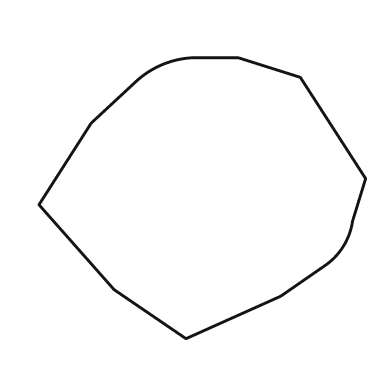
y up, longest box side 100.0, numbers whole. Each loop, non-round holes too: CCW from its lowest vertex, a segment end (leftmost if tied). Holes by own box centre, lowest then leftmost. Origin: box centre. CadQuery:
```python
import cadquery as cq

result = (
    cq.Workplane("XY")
    .moveTo(-5.0, -43.0)
    .lineTo(24.0, -30.0)
    .lineTo(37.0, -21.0)
    .threePointArc((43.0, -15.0), (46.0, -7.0))
    .lineTo(50.0, 6.0)
    .lineTo(30.0, 37.0)
    .lineTo(11.0, 43.0)
    .lineTo(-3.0, 43.0)
    .threePointArc((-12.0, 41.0), (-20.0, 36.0))
    .lineTo(-34.0, 23.0)
    .lineTo(-50.0, -2.0)
    .lineTo(-27.0, -28.0)
    .close()
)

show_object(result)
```